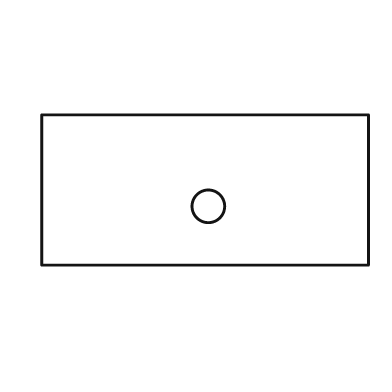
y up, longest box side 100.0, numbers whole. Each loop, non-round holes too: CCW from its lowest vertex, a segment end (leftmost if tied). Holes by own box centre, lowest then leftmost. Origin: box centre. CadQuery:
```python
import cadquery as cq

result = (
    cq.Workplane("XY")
    .moveTo(-50.0, -23.0)
    .lineTo(50.0, -23.0)
    .lineTo(50.0, 23.0)
    .lineTo(-50.0, 23.0)
    .close()
    .moveTo(1.0, -5.0)
    .circle(5.0)
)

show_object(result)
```